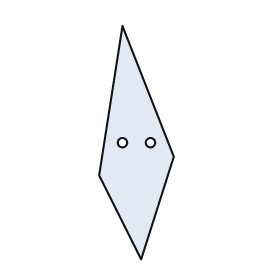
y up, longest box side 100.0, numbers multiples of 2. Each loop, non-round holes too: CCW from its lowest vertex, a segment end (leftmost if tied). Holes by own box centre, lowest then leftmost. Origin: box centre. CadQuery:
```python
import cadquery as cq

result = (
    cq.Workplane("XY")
    .moveTo(2.0, -50.0)
    .lineTo(16.0, -6.0)
    .lineTo(-6.0, 50.0)
    .lineTo(-16.0, -14.0)
    .close()
    .moveTo(-6.0, 0.0)
    .circle(2.0)
    .moveTo(6.0, 0.0)
    .circle(2.0)
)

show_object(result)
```